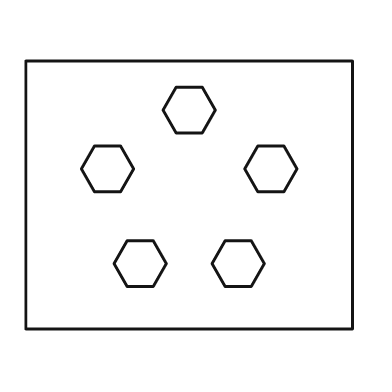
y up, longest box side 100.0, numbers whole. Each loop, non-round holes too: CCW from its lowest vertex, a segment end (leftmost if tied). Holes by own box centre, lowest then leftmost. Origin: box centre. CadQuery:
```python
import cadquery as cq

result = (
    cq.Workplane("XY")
    .moveTo(-50.0, -41.0)
    .lineTo(50.0, -41.0)
    .lineTo(50.0, 41.0)
    .lineTo(-50.0, 41.0)
    .close()
    .moveTo(-19.0, -28.0)
    .lineTo(-11.0, -28.0)
    .lineTo(-7.0, -21.0)
    .lineTo(-11.0, -14.0)
    .lineTo(-19.0, -14.0)
    .lineTo(-23.0, -21.0)
    .close()
    .moveTo(11.0, -28.0)
    .lineTo(19.0, -28.0)
    .lineTo(23.0, -21.0)
    .lineTo(19.0, -14.0)
    .lineTo(11.0, -14.0)
    .lineTo(7.0, -21.0)
    .close()
    .moveTo(-29.0, 1.0)
    .lineTo(-21.0, 1.0)
    .lineTo(-17.0, 8.0)
    .lineTo(-21.0, 15.0)
    .lineTo(-29.0, 15.0)
    .lineTo(-33.0, 8.0)
    .close()
    .moveTo(21.0, 1.0)
    .lineTo(29.0, 1.0)
    .lineTo(33.0, 8.0)
    .lineTo(29.0, 15.0)
    .lineTo(21.0, 15.0)
    .lineTo(17.0, 8.0)
    .close()
    .moveTo(-4.0, 19.0)
    .lineTo(4.0, 19.0)
    .lineTo(8.0, 26.0)
    .lineTo(4.0, 33.0)
    .lineTo(-4.0, 33.0)
    .lineTo(-8.0, 26.0)
    .close()
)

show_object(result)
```